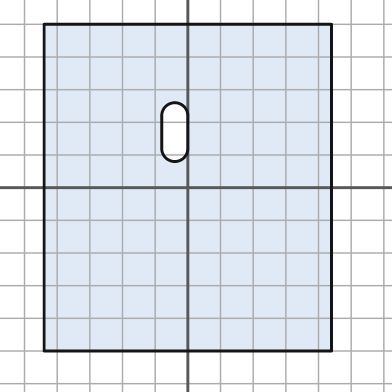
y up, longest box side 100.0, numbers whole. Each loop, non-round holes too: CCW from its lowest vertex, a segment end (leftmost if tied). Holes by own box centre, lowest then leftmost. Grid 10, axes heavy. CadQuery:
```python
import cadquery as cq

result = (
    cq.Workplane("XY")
    .moveTo(-44.0, -50.0)
    .lineTo(44.0, -50.0)
    .lineTo(44.0, 50.0)
    .lineTo(-44.0, 50.0)
    .close()
    .moveTo(-8.0, 12.0)
    .threePointArc((-4.0, 8.0), (0.0, 12.0))
    .lineTo(0.0, 22.0)
    .threePointArc((-4.0, 26.0), (-8.0, 22.0))
    .close()
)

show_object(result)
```